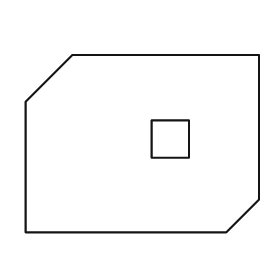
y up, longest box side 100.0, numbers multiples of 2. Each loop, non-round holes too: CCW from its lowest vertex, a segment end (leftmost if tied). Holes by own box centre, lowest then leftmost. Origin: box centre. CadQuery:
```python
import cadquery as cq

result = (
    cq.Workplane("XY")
    .moveTo(-50.0, -38.0)
    .lineTo(36.0, -38.0)
    .lineTo(50.0, -24.0)
    .lineTo(50.0, 38.0)
    .lineTo(-30.0, 38.0)
    .lineTo(-50.0, 18.0)
    .close()
    .moveTo(4.0, -6.0)
    .lineTo(20.0, -6.0)
    .lineTo(20.0, 10.0)
    .lineTo(4.0, 10.0)
    .close()
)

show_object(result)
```